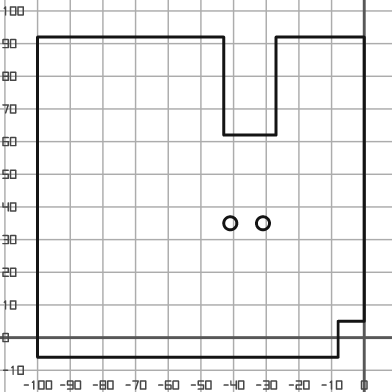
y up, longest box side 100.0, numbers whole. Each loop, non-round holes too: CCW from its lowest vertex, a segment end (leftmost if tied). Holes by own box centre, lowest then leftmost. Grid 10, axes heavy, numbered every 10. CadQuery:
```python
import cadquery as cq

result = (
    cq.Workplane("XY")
    .moveTo(-100.0, -6.0)
    .lineTo(-8.0, -6.0)
    .lineTo(-8.0, 5.0)
    .lineTo(0.0, 5.0)
    .lineTo(0.0, 92.0)
    .lineTo(-27.0, 92.0)
    .lineTo(-27.0, 62.0)
    .lineTo(-43.0, 62.0)
    .lineTo(-43.0, 92.0)
    .lineTo(-100.0, 92.0)
    .close()
    .moveTo(-41.0, 35.0)
    .circle(2.0)
    .moveTo(-31.0, 35.0)
    .circle(2.0)
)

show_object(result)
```